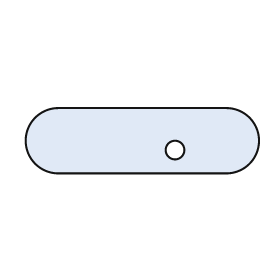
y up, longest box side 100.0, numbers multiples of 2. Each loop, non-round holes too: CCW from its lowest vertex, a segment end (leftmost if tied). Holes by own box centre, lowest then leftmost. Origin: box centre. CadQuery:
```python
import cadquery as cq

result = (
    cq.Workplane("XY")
    .moveTo(-36.0, -14.0)
    .lineTo(36.0, -14.0)
    .threePointArc((50.0, 0.0), (36.0, 14.0))
    .lineTo(-36.0, 14.0)
    .threePointArc((-50.0, 0.0), (-36.0, -14.0))
    .close()
    .moveTo(14.0, -4.0)
    .circle(4.0)
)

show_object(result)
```